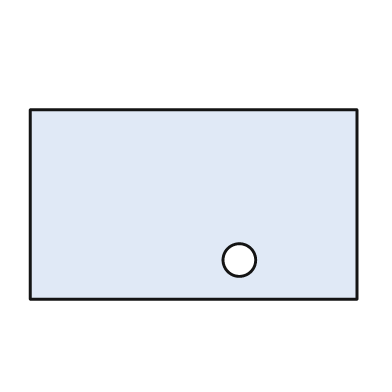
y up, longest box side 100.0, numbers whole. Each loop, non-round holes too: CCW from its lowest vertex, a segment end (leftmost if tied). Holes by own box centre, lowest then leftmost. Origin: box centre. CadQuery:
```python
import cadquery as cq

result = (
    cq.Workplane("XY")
    .moveTo(-50.0, -29.0)
    .lineTo(50.0, -29.0)
    .lineTo(50.0, 29.0)
    .lineTo(-50.0, 29.0)
    .close()
    .moveTo(14.0, -17.0)
    .circle(5.0)
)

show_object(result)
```